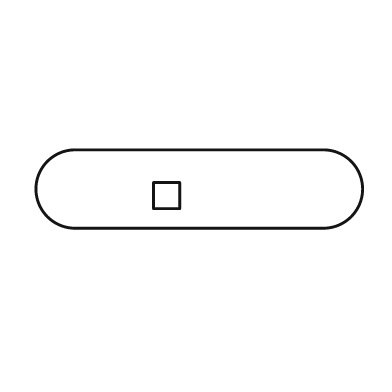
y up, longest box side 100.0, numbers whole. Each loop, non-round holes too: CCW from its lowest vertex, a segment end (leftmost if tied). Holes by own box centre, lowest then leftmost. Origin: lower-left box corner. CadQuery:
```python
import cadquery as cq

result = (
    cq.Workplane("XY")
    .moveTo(12.0, 0.0)
    .lineTo(88.0, 0.0)
    .threePointArc((100.0, 12.0), (88.0, 24.0))
    .lineTo(12.0, 24.0)
    .threePointArc((0.0, 12.0), (12.0, 0.0))
    .close()
    .moveTo(36.0, 6.0)
    .lineTo(44.0, 6.0)
    .lineTo(44.0, 14.0)
    .lineTo(36.0, 14.0)
    .close()
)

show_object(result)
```